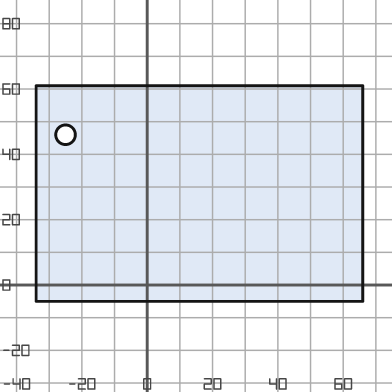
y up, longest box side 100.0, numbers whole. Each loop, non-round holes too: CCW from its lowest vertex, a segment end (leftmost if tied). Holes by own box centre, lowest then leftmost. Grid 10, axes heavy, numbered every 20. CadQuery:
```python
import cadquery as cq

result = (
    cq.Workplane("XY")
    .moveTo(-34.0, -5.0)
    .lineTo(66.0, -5.0)
    .lineTo(66.0, 61.0)
    .lineTo(-34.0, 61.0)
    .close()
    .moveTo(-25.0, 46.0)
    .circle(3.0)
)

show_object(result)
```